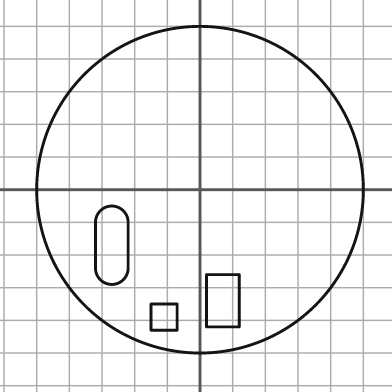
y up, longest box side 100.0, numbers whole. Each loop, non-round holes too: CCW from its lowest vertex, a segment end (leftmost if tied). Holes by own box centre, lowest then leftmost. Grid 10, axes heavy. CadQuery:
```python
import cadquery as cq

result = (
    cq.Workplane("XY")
    .moveTo(0.0, 0.0)
    .circle(50.0)
    .moveTo(-15.0, -43.0)
    .lineTo(-7.0, -43.0)
    .lineTo(-7.0, -35.0)
    .lineTo(-15.0, -35.0)
    .close()
    .moveTo(2.0, -42.0)
    .lineTo(12.0, -42.0)
    .lineTo(12.0, -26.0)
    .lineTo(2.0, -26.0)
    .close()
    .moveTo(-32.0, -24.0)
    .threePointArc((-27.0, -29.0), (-22.0, -24.0))
    .lineTo(-22.0, -10.0)
    .threePointArc((-27.0, -5.0), (-32.0, -10.0))
    .close()
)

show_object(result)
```